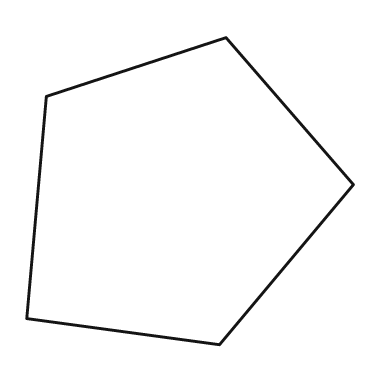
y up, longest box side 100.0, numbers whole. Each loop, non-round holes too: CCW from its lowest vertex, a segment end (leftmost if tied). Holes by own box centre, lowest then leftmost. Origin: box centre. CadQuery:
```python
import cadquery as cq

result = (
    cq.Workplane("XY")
    .moveTo(9.0, -47.0)
    .lineTo(50.0, 2.0)
    .lineTo(11.0, 47.0)
    .lineTo(-44.0, 29.0)
    .lineTo(-50.0, -39.0)
    .close()
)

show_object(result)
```